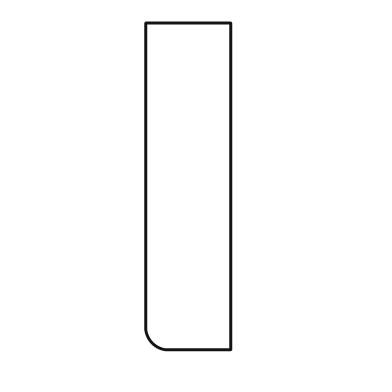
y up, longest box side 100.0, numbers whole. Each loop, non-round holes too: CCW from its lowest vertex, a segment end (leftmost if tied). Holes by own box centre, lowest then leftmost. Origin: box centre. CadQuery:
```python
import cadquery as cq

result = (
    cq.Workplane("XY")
    .moveTo(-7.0, -50.0)
    .lineTo(13.0, -50.0)
    .lineTo(13.0, 50.0)
    .lineTo(-13.0, 50.0)
    .lineTo(-13.0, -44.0)
    .threePointArc((-11.0, -48.0), (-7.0, -50.0))
    .close()
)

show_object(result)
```